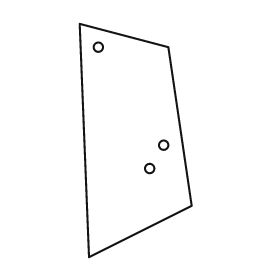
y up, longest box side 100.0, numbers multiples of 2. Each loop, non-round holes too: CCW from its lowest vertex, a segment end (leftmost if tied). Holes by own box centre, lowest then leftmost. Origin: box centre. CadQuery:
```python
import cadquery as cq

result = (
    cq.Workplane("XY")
    .moveTo(-20.0, -50.0)
    .lineTo(24.0, -28.0)
    .lineTo(14.0, 40.0)
    .lineTo(-24.0, 50.0)
    .close()
    .moveTo(6.0, -12.0)
    .circle(2.0)
    .moveTo(12.0, -2.0)
    .circle(2.0)
    .moveTo(-16.0, 40.0)
    .circle(2.0)
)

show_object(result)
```